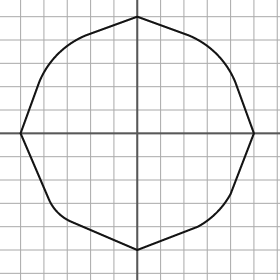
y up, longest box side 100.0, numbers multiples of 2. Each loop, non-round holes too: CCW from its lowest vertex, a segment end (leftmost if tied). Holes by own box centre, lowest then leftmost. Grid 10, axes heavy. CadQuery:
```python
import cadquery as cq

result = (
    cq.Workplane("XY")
    .moveTo(0.0, -50.0)
    .lineTo(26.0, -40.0)
    .threePointArc((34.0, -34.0), (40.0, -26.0))
    .lineTo(50.0, 0.0)
    .lineTo(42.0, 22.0)
    .threePointArc((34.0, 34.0), (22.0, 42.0))
    .lineTo(0.0, 50.0)
    .lineTo(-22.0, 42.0)
    .threePointArc((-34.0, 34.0), (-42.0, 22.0))
    .lineTo(-50.0, 0.0)
    .lineTo(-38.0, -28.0)
    .threePointArc((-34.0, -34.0), (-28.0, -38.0))
    .close()
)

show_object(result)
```